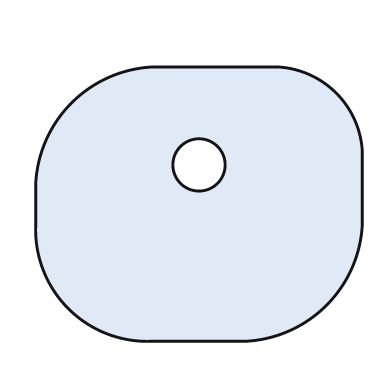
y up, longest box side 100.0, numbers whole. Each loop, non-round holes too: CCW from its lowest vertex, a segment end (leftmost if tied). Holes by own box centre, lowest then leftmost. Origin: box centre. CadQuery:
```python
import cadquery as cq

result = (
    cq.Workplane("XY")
    .moveTo(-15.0, -42.0)
    .lineTo(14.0, -42.0)
    .threePointArc((39.0, -31.0), (50.0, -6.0))
    .lineTo(50.0, 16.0)
    .threePointArc((42.0, 34.0), (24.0, 42.0))
    .lineTo(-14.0, 42.0)
    .threePointArc((-39.0, 31.0), (-50.0, 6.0))
    .lineTo(-50.0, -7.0)
    .threePointArc((-40.0, -32.0), (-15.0, -42.0))
    .close()
    .moveTo(0.0, 12.0)
    .circle(8.0)
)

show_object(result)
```